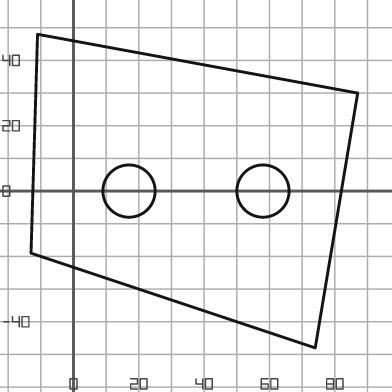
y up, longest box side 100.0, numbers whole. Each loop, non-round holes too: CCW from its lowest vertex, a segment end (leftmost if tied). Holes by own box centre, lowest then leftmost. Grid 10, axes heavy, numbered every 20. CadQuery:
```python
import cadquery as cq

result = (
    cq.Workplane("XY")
    .moveTo(74.0, -48.0)
    .lineTo(87.0, 30.0)
    .lineTo(-11.0, 48.0)
    .lineTo(-13.0, -19.0)
    .close()
    .moveTo(17.0, 0.0)
    .circle(8.0)
    .moveTo(58.0, 0.0)
    .circle(8.0)
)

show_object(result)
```